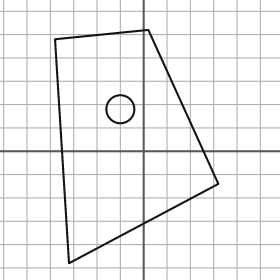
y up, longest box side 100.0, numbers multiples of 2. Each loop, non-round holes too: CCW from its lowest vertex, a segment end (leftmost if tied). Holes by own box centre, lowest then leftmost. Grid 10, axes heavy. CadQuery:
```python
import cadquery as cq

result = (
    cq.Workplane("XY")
    .moveTo(-32.0, -48.0)
    .lineTo(32.0, -14.0)
    .lineTo(2.0, 52.0)
    .lineTo(-38.0, 48.0)
    .close()
    .moveTo(-10.0, 18.0)
    .circle(6.0)
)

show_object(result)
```